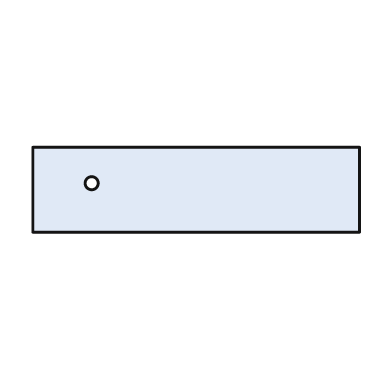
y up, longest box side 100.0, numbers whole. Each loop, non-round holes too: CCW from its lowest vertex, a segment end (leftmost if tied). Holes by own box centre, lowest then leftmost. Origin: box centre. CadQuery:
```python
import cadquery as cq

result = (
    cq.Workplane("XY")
    .moveTo(-50.0, -13.0)
    .lineTo(50.0, -13.0)
    .lineTo(50.0, 13.0)
    .lineTo(-50.0, 13.0)
    .close()
    .moveTo(-32.0, 2.0)
    .circle(2.0)
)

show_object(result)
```